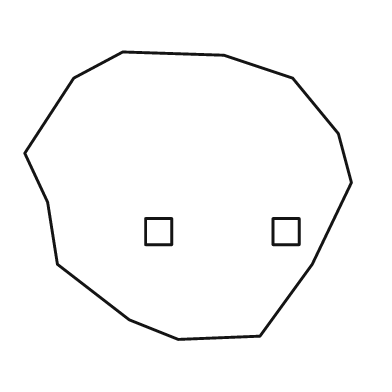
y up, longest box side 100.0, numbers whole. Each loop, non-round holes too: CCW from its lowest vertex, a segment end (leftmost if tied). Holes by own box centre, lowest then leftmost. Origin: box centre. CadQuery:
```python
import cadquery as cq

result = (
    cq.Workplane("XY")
    .moveTo(-3.0, -44.0)
    .lineTo(22.0, -43.0)
    .lineTo(38.0, -21.0)
    .lineTo(50.0, 4.0)
    .lineTo(46.0, 19.0)
    .lineTo(32.0, 36.0)
    .lineTo(11.0, 43.0)
    .lineTo(-20.0, 44.0)
    .lineTo(-35.0, 36.0)
    .lineTo(-50.0, 13.0)
    .lineTo(-43.0, -2.0)
    .lineTo(-40.0, -21.0)
    .lineTo(-18.0, -38.0)
    .close()
    .moveTo(-13.0, -15.0)
    .lineTo(-5.0, -15.0)
    .lineTo(-5.0, -7.0)
    .lineTo(-13.0, -7.0)
    .close()
    .moveTo(26.0, -15.0)
    .lineTo(34.0, -15.0)
    .lineTo(34.0, -7.0)
    .lineTo(26.0, -7.0)
    .close()
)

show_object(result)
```